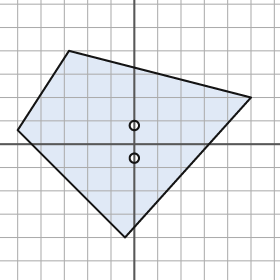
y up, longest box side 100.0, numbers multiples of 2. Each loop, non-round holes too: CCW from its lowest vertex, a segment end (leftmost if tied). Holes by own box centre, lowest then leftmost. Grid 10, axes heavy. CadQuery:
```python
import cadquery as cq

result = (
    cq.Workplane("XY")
    .moveTo(-4.0, -40.0)
    .lineTo(50.0, 20.0)
    .lineTo(-28.0, 40.0)
    .lineTo(-50.0, 6.0)
    .close()
    .moveTo(0.0, -6.0)
    .circle(2.0)
    .moveTo(0.0, 8.0)
    .circle(2.0)
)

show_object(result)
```